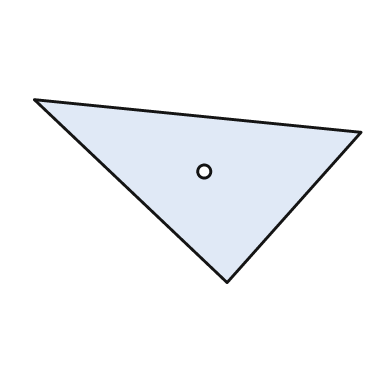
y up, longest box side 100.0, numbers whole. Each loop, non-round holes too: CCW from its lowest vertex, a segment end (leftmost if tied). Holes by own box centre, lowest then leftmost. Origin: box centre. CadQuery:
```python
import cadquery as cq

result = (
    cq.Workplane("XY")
    .moveTo(9.0, -28.0)
    .lineTo(50.0, 18.0)
    .lineTo(-50.0, 28.0)
    .close()
    .moveTo(2.0, 6.0)
    .circle(2.0)
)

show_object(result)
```